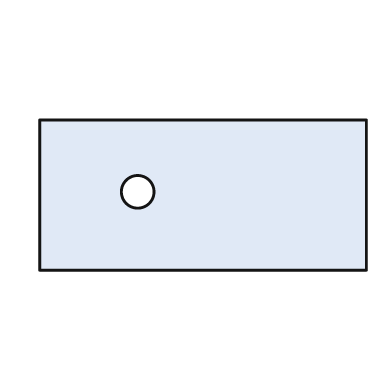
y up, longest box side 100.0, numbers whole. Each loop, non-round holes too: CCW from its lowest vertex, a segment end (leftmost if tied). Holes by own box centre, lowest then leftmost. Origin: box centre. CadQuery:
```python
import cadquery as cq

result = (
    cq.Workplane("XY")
    .moveTo(-50.0, -23.0)
    .lineTo(50.0, -23.0)
    .lineTo(50.0, 23.0)
    .lineTo(-50.0, 23.0)
    .close()
    .moveTo(-20.0, 1.0)
    .circle(5.0)
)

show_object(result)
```